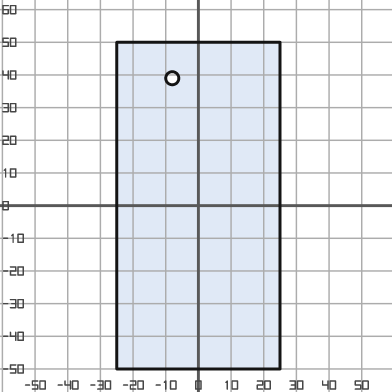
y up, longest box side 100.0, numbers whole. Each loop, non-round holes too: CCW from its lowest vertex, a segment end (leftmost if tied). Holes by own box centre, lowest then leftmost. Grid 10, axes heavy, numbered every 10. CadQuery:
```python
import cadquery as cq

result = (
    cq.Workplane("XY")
    .moveTo(-25.0, -50.0)
    .lineTo(25.0, -50.0)
    .lineTo(25.0, 50.0)
    .lineTo(-25.0, 50.0)
    .close()
    .moveTo(-8.0, 39.0)
    .circle(2.0)
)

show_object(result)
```